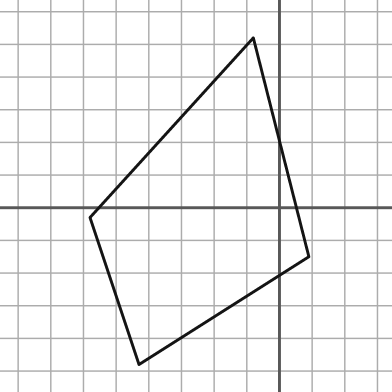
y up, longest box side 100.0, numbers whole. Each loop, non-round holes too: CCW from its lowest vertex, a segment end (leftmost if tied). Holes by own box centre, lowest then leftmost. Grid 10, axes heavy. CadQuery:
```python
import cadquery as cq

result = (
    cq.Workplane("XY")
    .moveTo(-43.0, -48.0)
    .lineTo(9.0, -15.0)
    .lineTo(-8.0, 52.0)
    .lineTo(-58.0, -3.0)
    .close()
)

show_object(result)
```